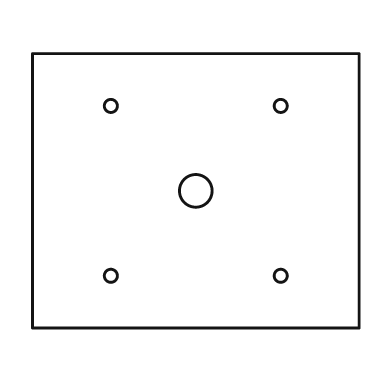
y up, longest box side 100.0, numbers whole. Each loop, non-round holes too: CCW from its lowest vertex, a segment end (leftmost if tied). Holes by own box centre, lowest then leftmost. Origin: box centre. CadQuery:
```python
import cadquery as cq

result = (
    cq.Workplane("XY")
    .moveTo(-50.0, -42.0)
    .lineTo(50.0, -42.0)
    .lineTo(50.0, 42.0)
    .lineTo(-50.0, 42.0)
    .close()
    .moveTo(-26.0, -26.0)
    .circle(2.0)
    .moveTo(26.0, -26.0)
    .circle(2.0)
    .moveTo(0.0, 0.0)
    .circle(5.0)
    .moveTo(-26.0, 26.0)
    .circle(2.0)
    .moveTo(26.0, 26.0)
    .circle(2.0)
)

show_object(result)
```